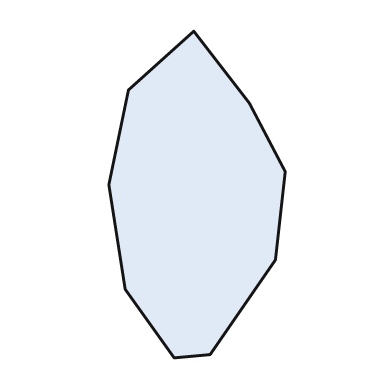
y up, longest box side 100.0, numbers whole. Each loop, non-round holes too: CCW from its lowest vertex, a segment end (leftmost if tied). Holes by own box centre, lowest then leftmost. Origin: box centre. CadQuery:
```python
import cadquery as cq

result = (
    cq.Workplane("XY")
    .moveTo(-7.0, -50.0)
    .lineTo(4.0, -49.0)
    .lineTo(24.0, -20.0)
    .lineTo(27.0, 7.0)
    .lineTo(16.0, 28.0)
    .lineTo(-1.0, 50.0)
    .lineTo(-21.0, 32.0)
    .lineTo(-27.0, 3.0)
    .lineTo(-22.0, -29.0)
    .close()
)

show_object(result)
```